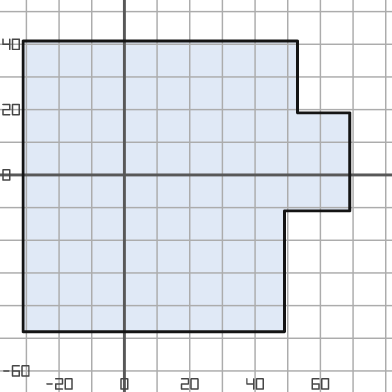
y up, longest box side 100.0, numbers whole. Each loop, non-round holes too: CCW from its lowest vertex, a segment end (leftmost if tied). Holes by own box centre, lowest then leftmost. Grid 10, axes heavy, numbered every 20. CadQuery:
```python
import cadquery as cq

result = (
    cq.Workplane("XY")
    .moveTo(-31.0, -48.0)
    .lineTo(49.0, -48.0)
    .lineTo(49.0, -11.0)
    .lineTo(69.0, -11.0)
    .lineTo(69.0, 19.0)
    .lineTo(53.0, 19.0)
    .lineTo(53.0, 41.0)
    .lineTo(-31.0, 41.0)
    .close()
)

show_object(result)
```